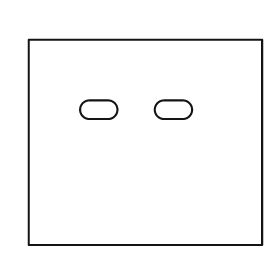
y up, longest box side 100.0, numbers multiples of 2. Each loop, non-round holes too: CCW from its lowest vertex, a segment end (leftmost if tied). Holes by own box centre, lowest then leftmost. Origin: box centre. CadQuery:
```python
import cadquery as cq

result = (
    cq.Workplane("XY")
    .moveTo(-50.0, -44.0)
    .lineTo(50.0, -44.0)
    .lineTo(50.0, 44.0)
    .lineTo(-50.0, 44.0)
    .close()
    .moveTo(-24.0, 10.0)
    .lineTo(-16.0, 10.0)
    .threePointArc((-12.0, 14.0), (-16.0, 18.0))
    .lineTo(-24.0, 18.0)
    .threePointArc((-28.0, 14.0), (-24.0, 10.0))
    .close()
    .moveTo(8.0, 10.0)
    .lineTo(16.0, 10.0)
    .threePointArc((20.0, 14.0), (16.0, 18.0))
    .lineTo(8.0, 18.0)
    .threePointArc((4.0, 14.0), (8.0, 10.0))
    .close()
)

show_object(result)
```